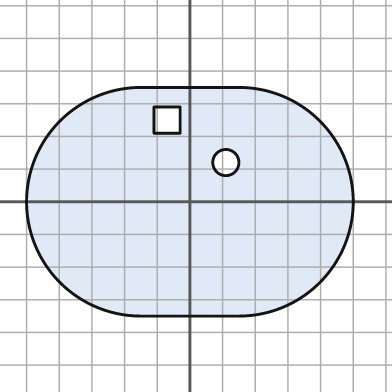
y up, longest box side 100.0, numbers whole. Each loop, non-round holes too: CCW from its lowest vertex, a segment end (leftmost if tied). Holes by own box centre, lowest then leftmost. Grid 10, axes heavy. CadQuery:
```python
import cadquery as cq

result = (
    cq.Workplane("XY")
    .moveTo(-15.0, -35.0)
    .lineTo(15.0, -35.0)
    .threePointArc((50.0, 0.0), (15.0, 35.0))
    .lineTo(-15.0, 35.0)
    .threePointArc((-50.0, 0.0), (-15.0, -35.0))
    .close()
    .moveTo(11.0, 12.0)
    .circle(4.0)
    .moveTo(-11.0, 21.0)
    .lineTo(-3.0, 21.0)
    .lineTo(-3.0, 29.0)
    .lineTo(-11.0, 29.0)
    .close()
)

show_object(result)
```